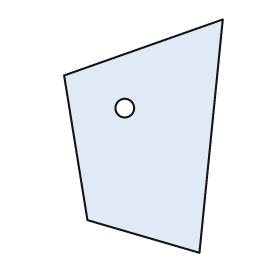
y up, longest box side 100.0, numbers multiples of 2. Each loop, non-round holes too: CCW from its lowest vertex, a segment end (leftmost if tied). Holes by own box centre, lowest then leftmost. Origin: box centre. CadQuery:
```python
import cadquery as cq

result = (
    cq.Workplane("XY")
    .moveTo(24.0, -50.0)
    .lineTo(34.0, 50.0)
    .lineTo(-34.0, 26.0)
    .lineTo(-24.0, -36.0)
    .close()
    .moveTo(-8.0, 12.0)
    .circle(4.0)
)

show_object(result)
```